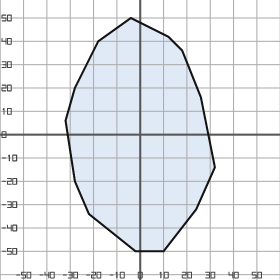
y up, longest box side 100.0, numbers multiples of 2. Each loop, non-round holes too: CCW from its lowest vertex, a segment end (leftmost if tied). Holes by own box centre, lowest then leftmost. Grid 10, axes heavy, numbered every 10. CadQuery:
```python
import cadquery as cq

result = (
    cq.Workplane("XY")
    .moveTo(-2.0, -50.0)
    .lineTo(10.0, -50.0)
    .lineTo(24.0, -32.0)
    .lineTo(32.0, -14.0)
    .lineTo(26.0, 16.0)
    .lineTo(18.0, 36.0)
    .lineTo(12.0, 42.0)
    .lineTo(-4.0, 50.0)
    .lineTo(-18.0, 40.0)
    .lineTo(-28.0, 20.0)
    .lineTo(-32.0, 6.0)
    .lineTo(-28.0, -20.0)
    .lineTo(-22.0, -34.0)
    .close()
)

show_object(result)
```